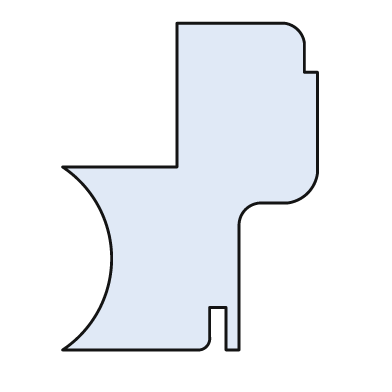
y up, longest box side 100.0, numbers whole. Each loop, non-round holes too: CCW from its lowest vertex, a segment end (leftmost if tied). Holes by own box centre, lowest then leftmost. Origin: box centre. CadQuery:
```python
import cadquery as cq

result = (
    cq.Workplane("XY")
    .moveTo(-39.0, -50.0)
    .lineTo(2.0, -50.0)
    .threePointArc((5.0, -49.0), (6.0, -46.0))
    .lineTo(6.0, -37.0)
    .lineTo(11.0, -37.0)
    .lineTo(11.0, -50.0)
    .lineTo(15.0, -50.0)
    .lineTo(15.0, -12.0)
    .threePointArc((17.0, -7.0), (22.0, -5.0))
    .lineTo(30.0, -5.0)
    .threePointArc((36.0, -2.0), (39.0, 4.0))
    .lineTo(39.0, 35.0)
    .lineTo(35.0, 35.0)
    .lineTo(35.0, 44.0)
    .threePointArc((33.0, 48.0), (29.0, 50.0))
    .lineTo(-4.0, 50.0)
    .lineTo(-4.0, 6.0)
    .lineTo(-39.0, 6.0)
    .threePointArc((-24.0, -22.0), (-39.0, -50.0))
    .close()
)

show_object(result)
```